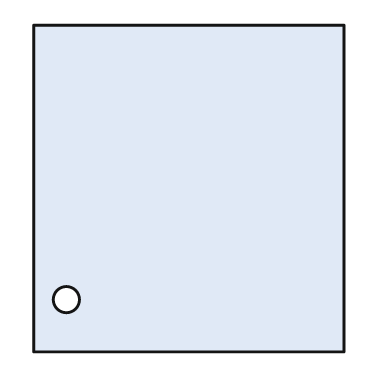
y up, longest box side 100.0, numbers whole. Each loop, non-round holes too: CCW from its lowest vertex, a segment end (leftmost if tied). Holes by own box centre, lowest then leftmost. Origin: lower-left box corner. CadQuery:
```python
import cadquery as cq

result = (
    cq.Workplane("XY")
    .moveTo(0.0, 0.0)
    .lineTo(95.0, 0.0)
    .lineTo(95.0, 100.0)
    .lineTo(0.0, 100.0)
    .close()
    .moveTo(10.0, 16.0)
    .circle(4.0)
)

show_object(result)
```